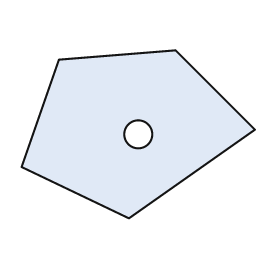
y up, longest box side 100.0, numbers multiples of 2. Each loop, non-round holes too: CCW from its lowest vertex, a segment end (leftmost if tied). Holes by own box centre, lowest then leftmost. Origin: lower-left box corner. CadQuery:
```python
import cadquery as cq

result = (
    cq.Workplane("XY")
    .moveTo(46.0, 0.0)
    .lineTo(100.0, 38.0)
    .lineTo(66.0, 72.0)
    .lineTo(16.0, 68.0)
    .lineTo(0.0, 22.0)
    .close()
    .moveTo(50.0, 36.0)
    .circle(6.0)
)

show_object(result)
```